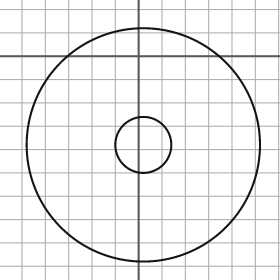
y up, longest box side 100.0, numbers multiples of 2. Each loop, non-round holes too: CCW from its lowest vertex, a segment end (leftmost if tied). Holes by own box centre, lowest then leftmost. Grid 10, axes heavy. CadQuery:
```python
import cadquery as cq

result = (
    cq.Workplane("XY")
    .moveTo(2.0, -38.0)
    .circle(50.0)
    .moveTo(2.0, -38.0)
    .circle(12.0)
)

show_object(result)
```